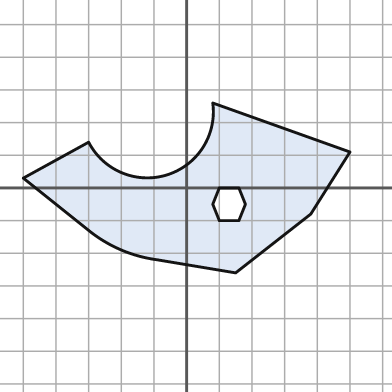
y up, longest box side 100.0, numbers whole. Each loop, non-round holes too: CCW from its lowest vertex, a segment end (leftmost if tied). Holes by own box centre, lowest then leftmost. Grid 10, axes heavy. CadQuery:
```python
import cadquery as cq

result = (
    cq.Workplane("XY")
    .moveTo(15.0, -26.0)
    .lineTo(38.0, -8.0)
    .lineTo(50.0, 11.0)
    .lineTo(8.0, 26.0)
    .threePointArc((-6.0, 4.0), (-30.0, 14.0))
    .lineTo(-50.0, 3.0)
    .lineTo(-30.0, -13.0)
    .threePointArc((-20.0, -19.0), (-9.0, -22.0))
    .close()
    .moveTo(10.0, -10.0)
    .lineTo(16.0, -10.0)
    .lineTo(18.0, -5.0)
    .lineTo(16.0, 0.0)
    .lineTo(10.0, 0.0)
    .lineTo(8.0, -5.0)
    .close()
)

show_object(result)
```